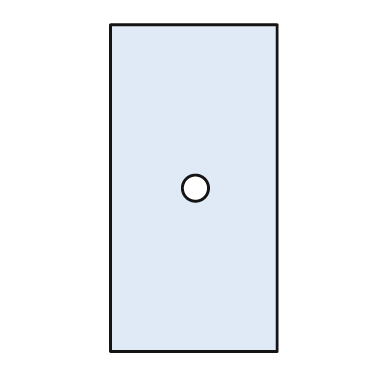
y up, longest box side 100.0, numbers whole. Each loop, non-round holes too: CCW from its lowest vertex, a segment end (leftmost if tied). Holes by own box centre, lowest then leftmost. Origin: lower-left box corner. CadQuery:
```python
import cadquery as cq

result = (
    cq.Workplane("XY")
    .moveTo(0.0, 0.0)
    .lineTo(51.0, 0.0)
    .lineTo(51.0, 100.0)
    .lineTo(0.0, 100.0)
    .close()
    .moveTo(26.0, 50.0)
    .circle(4.0)
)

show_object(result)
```